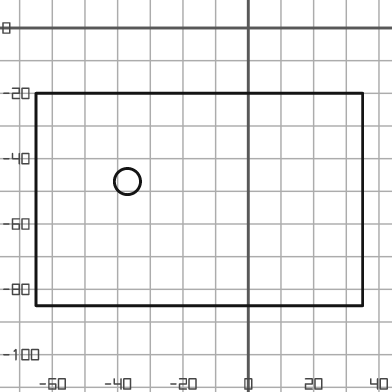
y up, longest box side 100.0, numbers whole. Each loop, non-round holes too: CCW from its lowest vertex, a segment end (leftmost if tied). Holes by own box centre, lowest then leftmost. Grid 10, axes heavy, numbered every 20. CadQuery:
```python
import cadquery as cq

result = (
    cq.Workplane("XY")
    .moveTo(-65.0, -85.0)
    .lineTo(35.0, -85.0)
    .lineTo(35.0, -20.0)
    .lineTo(-65.0, -20.0)
    .close()
    .moveTo(-37.0, -47.0)
    .circle(4.0)
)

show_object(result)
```